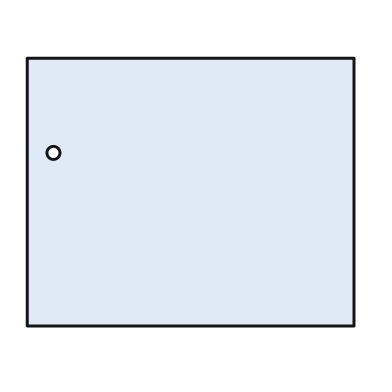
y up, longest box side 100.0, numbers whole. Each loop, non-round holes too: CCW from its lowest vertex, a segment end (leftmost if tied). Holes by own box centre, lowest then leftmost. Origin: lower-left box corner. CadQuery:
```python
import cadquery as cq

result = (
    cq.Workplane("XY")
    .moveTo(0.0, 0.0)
    .lineTo(100.0, 0.0)
    .lineTo(100.0, 82.0)
    .lineTo(0.0, 82.0)
    .close()
    .moveTo(8.0, 53.0)
    .circle(2.0)
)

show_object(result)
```